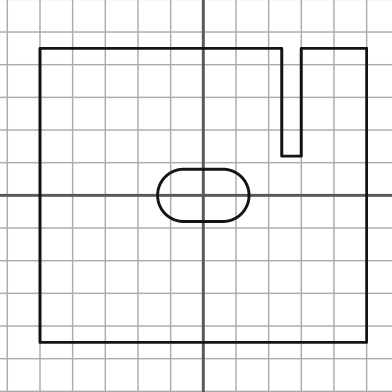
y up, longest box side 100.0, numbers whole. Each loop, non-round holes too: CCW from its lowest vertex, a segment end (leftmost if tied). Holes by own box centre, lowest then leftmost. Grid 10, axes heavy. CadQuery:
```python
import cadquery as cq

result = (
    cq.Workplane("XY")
    .moveTo(-50.0, -45.0)
    .lineTo(50.0, -45.0)
    .lineTo(50.0, 45.0)
    .lineTo(30.0, 45.0)
    .lineTo(30.0, 12.0)
    .lineTo(24.0, 12.0)
    .lineTo(24.0, 45.0)
    .lineTo(-50.0, 45.0)
    .close()
    .moveTo(-6.0, -8.0)
    .lineTo(6.0, -8.0)
    .threePointArc((14.0, 0.0), (6.0, 8.0))
    .lineTo(-6.0, 8.0)
    .threePointArc((-14.0, 0.0), (-6.0, -8.0))
    .close()
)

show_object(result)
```